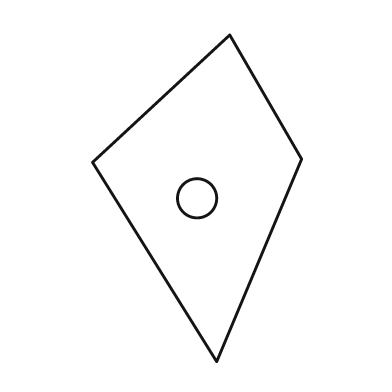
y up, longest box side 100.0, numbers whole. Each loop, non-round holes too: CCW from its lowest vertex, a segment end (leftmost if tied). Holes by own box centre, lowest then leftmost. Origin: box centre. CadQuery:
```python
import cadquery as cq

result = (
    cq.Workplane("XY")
    .moveTo(6.0, -50.0)
    .lineTo(32.0, 12.0)
    .lineTo(10.0, 50.0)
    .lineTo(-32.0, 11.0)
    .close()
    .moveTo(0.0, 0.0)
    .circle(6.0)
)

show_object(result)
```